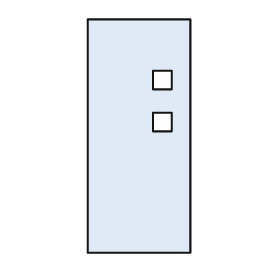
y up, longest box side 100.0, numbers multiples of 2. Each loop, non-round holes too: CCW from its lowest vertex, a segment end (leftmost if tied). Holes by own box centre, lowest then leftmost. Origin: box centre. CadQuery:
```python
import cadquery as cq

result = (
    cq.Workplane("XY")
    .moveTo(-22.0, -50.0)
    .lineTo(22.0, -50.0)
    .lineTo(22.0, 50.0)
    .lineTo(-22.0, 50.0)
    .close()
    .moveTo(6.0, 2.0)
    .lineTo(14.0, 2.0)
    .lineTo(14.0, 10.0)
    .lineTo(6.0, 10.0)
    .close()
    .moveTo(6.0, 20.0)
    .lineTo(14.0, 20.0)
    .lineTo(14.0, 28.0)
    .lineTo(6.0, 28.0)
    .close()
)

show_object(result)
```